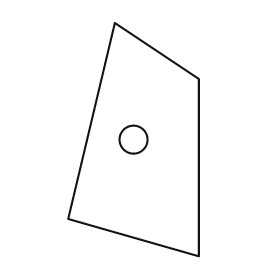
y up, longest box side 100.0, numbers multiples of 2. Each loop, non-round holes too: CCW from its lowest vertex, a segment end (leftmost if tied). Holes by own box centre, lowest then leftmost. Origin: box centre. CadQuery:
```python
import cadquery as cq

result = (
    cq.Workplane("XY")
    .moveTo(28.0, -50.0)
    .lineTo(28.0, 26.0)
    .lineTo(-8.0, 50.0)
    .lineTo(-28.0, -34.0)
    .close()
    .moveTo(0.0, 0.0)
    .circle(6.0)
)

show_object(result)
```